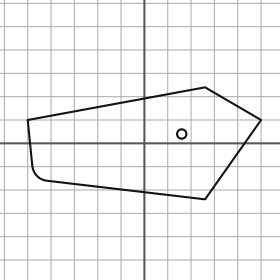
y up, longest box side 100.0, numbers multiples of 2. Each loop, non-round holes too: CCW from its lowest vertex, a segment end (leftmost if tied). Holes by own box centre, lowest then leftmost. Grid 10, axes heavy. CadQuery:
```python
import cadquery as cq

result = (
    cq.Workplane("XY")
    .moveTo(26.0, -24.0)
    .lineTo(50.0, 10.0)
    .lineTo(26.0, 24.0)
    .lineTo(-50.0, 10.0)
    .lineTo(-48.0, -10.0)
    .threePointArc((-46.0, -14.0), (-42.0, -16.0))
    .close()
    .moveTo(16.0, 4.0)
    .circle(2.0)
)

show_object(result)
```